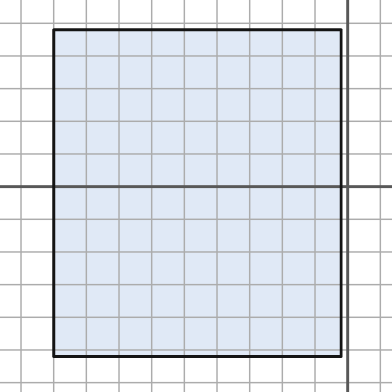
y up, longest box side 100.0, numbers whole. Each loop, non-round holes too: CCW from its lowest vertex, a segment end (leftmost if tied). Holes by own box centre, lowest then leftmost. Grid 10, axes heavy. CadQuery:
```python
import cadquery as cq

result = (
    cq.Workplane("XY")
    .moveTo(-90.0, -52.0)
    .lineTo(-2.0, -52.0)
    .lineTo(-2.0, 48.0)
    .lineTo(-90.0, 48.0)
    .close()
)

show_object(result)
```